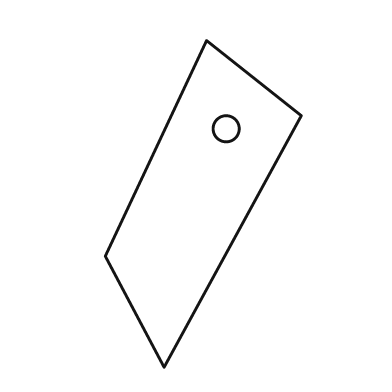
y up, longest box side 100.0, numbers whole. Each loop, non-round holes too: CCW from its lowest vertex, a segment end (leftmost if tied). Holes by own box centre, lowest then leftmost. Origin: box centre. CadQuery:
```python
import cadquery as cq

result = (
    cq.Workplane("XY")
    .moveTo(-12.0, -50.0)
    .lineTo(30.0, 27.0)
    .lineTo(1.0, 50.0)
    .lineTo(-30.0, -16.0)
    .close()
    .moveTo(7.0, 23.0)
    .circle(4.0)
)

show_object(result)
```